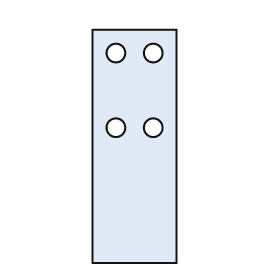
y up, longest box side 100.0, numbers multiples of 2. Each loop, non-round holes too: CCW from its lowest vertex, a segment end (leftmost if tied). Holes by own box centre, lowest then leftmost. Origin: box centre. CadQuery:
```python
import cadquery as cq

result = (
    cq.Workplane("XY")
    .moveTo(-18.0, -50.0)
    .lineTo(18.0, -50.0)
    .lineTo(18.0, 50.0)
    .lineTo(-18.0, 50.0)
    .close()
    .moveTo(-8.0, 8.0)
    .circle(4.0)
    .moveTo(8.0, 8.0)
    .circle(4.0)
    .moveTo(-8.0, 40.0)
    .circle(4.0)
    .moveTo(8.0, 40.0)
    .circle(4.0)
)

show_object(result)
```